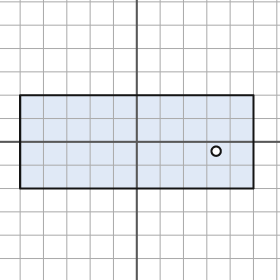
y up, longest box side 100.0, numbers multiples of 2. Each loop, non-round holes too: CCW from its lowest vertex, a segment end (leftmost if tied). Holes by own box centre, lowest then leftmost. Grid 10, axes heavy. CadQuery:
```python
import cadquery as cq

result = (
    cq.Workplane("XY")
    .moveTo(-50.0, -20.0)
    .lineTo(50.0, -20.0)
    .lineTo(50.0, 20.0)
    .lineTo(-50.0, 20.0)
    .close()
    .moveTo(34.0, -4.0)
    .circle(2.0)
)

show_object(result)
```